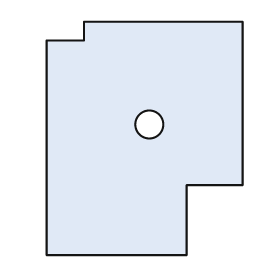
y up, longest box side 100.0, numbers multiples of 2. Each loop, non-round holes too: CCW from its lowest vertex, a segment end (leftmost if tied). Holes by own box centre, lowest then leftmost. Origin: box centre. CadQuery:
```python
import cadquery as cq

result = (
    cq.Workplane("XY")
    .moveTo(-42.0, -50.0)
    .lineTo(18.0, -50.0)
    .lineTo(18.0, -20.0)
    .lineTo(42.0, -20.0)
    .lineTo(42.0, 50.0)
    .lineTo(-26.0, 50.0)
    .lineTo(-26.0, 42.0)
    .lineTo(-42.0, 42.0)
    .close()
    .moveTo(2.0, 6.0)
    .circle(6.0)
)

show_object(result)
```